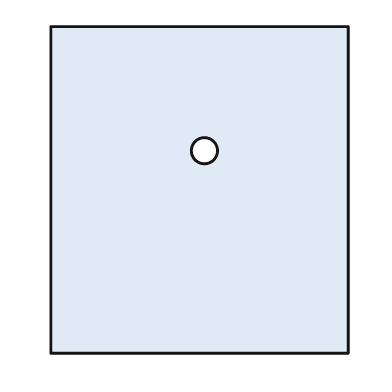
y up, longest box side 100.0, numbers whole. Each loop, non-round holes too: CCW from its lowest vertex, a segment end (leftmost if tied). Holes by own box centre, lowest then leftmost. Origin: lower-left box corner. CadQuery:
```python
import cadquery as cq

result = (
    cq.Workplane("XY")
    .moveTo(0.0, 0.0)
    .lineTo(91.0, 0.0)
    .lineTo(91.0, 100.0)
    .lineTo(0.0, 100.0)
    .close()
    .moveTo(47.0, 62.0)
    .circle(4.0)
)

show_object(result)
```